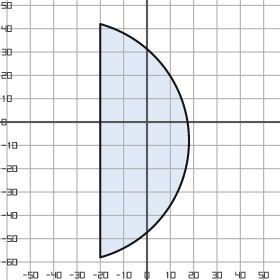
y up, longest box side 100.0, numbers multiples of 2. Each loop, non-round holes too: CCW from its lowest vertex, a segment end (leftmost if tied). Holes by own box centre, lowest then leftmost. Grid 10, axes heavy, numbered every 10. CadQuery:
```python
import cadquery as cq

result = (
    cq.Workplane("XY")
    .moveTo(-20.0, -58.0)
    .threePointArc((18.0, -8.0), (-20.0, 42.0))
    .close()
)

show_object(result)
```